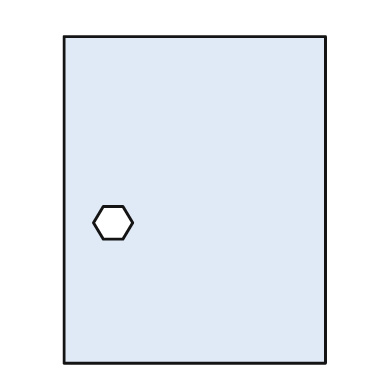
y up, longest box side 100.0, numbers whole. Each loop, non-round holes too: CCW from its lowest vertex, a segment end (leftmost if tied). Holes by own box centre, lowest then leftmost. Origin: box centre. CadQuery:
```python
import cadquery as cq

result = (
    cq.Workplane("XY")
    .moveTo(-40.0, -50.0)
    .lineTo(40.0, -50.0)
    .lineTo(40.0, 50.0)
    .lineTo(-40.0, 50.0)
    .close()
    .moveTo(-28.0, -12.0)
    .lineTo(-22.0, -12.0)
    .lineTo(-19.0, -7.0)
    .lineTo(-22.0, -2.0)
    .lineTo(-28.0, -2.0)
    .lineTo(-31.0, -7.0)
    .close()
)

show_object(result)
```